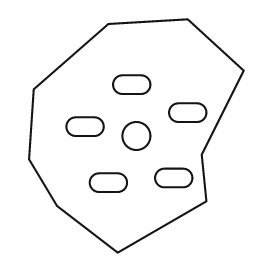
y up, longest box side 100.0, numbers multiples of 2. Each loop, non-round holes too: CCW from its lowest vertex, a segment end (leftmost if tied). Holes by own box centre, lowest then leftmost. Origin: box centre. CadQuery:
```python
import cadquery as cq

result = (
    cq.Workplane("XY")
    .moveTo(-8.0, -50.0)
    .lineTo(30.0, -28.0)
    .lineTo(28.0, -8.0)
    .lineTo(46.0, 28.0)
    .lineTo(22.0, 50.0)
    .lineTo(-12.0, 48.0)
    .lineTo(-44.0, 20.0)
    .lineTo(-46.0, -10.0)
    .lineTo(-34.0, -30.0)
    .close()
    .moveTo(-16.0, -24.0)
    .lineTo(-8.0, -24.0)
    .threePointArc((-4.0, -20.0), (-8.0, -16.0))
    .lineTo(-16.0, -16.0)
    .threePointArc((-20.0, -20.0), (-16.0, -24.0))
    .close()
    .moveTo(12.0, -22.0)
    .lineTo(20.0, -22.0)
    .threePointArc((24.0, -18.0), (20.0, -14.0))
    .lineTo(12.0, -14.0)
    .threePointArc((8.0, -18.0), (12.0, -22.0))
    .close()
    .moveTo(0.0, 0.0)
    .circle(6.0)
    .moveTo(-26.0, 0.0)
    .lineTo(-18.0, 0.0)
    .threePointArc((-14.0, 4.0), (-18.0, 8.0))
    .lineTo(-26.0, 8.0)
    .threePointArc((-30.0, 4.0), (-26.0, 0.0))
    .close()
    .moveTo(18.0, 6.0)
    .lineTo(26.0, 6.0)
    .threePointArc((30.0, 10.0), (26.0, 14.0))
    .lineTo(18.0, 14.0)
    .threePointArc((14.0, 10.0), (18.0, 6.0))
    .close()
    .moveTo(-6.0, 18.0)
    .lineTo(2.0, 18.0)
    .threePointArc((6.0, 22.0), (2.0, 26.0))
    .lineTo(-6.0, 26.0)
    .threePointArc((-10.0, 22.0), (-6.0, 18.0))
    .close()
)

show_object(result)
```